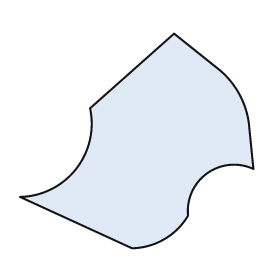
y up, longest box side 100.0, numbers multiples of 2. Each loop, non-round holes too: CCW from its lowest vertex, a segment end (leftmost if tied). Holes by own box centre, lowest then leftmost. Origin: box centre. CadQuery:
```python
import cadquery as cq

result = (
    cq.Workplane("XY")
    .moveTo(-2.0, -46.0)
    .threePointArc((12.0, -42.0), (22.0, -32.0))
    .threePointArc((30.0, -14.0), (50.0, -12.0))
    .lineTo(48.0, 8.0)
    .threePointArc((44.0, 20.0), (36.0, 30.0))
    .lineTo(16.0, 46.0)
    .lineTo(-20.0, 14.0)
    .threePointArc((-26.0, -12.0), (-50.0, -24.0))
    .close()
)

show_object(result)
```